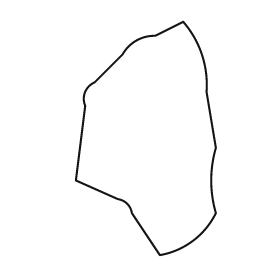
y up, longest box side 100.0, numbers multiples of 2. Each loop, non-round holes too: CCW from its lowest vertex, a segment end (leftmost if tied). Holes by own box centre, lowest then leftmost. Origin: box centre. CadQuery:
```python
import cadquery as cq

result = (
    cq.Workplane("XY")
    .moveTo(6.0, -50.0)
    .threePointArc((20.0, -44.0), (30.0, -32.0))
    .threePointArc((28.0, -18.0), (30.0, -4.0))
    .lineTo(26.0, 20.0)
    .threePointArc((24.0, 36.0), (16.0, 50.0))
    .lineTo(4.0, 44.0)
    .threePointArc((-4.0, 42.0), (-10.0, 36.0))
    .lineTo(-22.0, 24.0)
    .threePointArc((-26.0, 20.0), (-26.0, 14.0))
    .lineTo(-30.0, -18.0)
    .lineTo(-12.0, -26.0)
    .threePointArc((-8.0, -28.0), (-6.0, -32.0))
    .close()
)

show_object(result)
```